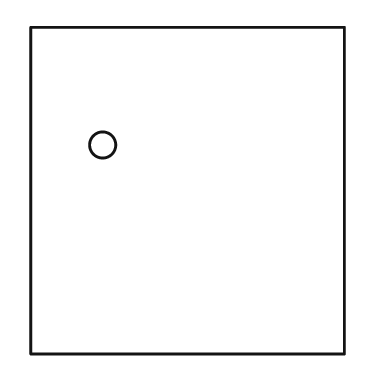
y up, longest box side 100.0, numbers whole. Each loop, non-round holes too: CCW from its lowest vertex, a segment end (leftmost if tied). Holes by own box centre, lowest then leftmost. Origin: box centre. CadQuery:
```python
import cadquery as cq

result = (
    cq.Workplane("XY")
    .moveTo(-48.0, -50.0)
    .lineTo(48.0, -50.0)
    .lineTo(48.0, 50.0)
    .lineTo(-48.0, 50.0)
    .close()
    .moveTo(-26.0, 14.0)
    .circle(4.0)
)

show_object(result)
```